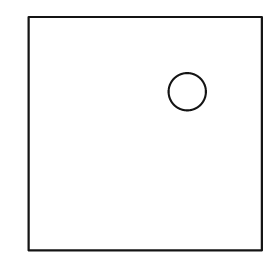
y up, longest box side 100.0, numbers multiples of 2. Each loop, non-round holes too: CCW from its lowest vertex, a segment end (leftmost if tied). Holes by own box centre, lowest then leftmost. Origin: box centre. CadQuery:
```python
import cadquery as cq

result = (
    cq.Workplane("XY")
    .moveTo(-50.0, -50.0)
    .lineTo(50.0, -50.0)
    .lineTo(50.0, 50.0)
    .lineTo(-50.0, 50.0)
    .close()
    .moveTo(18.0, 18.0)
    .circle(8.0)
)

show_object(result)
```